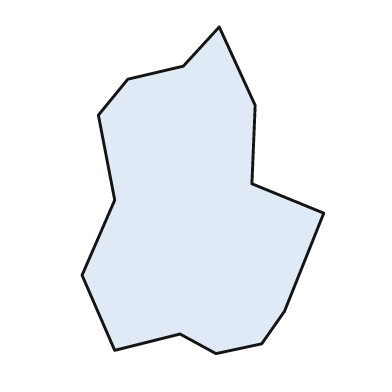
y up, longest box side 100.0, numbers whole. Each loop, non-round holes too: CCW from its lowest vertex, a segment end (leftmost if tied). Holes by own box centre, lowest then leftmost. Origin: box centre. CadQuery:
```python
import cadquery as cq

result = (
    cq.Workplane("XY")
    .moveTo(4.0, -50.0)
    .lineTo(18.0, -47.0)
    .lineTo(25.0, -37.0)
    .lineTo(37.0, -7.0)
    .lineTo(15.0, 2.0)
    .lineTo(16.0, 26.0)
    .lineTo(5.0, 50.0)
    .lineTo(-6.0, 38.0)
    .lineTo(-23.0, 34.0)
    .lineTo(-32.0, 23.0)
    .lineTo(-27.0, -3.0)
    .lineTo(-37.0, -26.0)
    .lineTo(-27.0, -49.0)
    .lineTo(-7.0, -44.0)
    .close()
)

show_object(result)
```